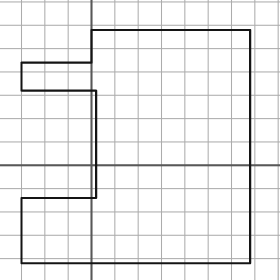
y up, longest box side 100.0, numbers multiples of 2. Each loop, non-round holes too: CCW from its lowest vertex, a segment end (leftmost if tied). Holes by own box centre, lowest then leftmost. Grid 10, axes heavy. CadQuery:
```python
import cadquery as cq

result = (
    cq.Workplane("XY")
    .moveTo(-30.0, -42.0)
    .lineTo(68.0, -42.0)
    .lineTo(68.0, 58.0)
    .lineTo(0.0, 58.0)
    .lineTo(0.0, 44.0)
    .lineTo(-30.0, 44.0)
    .lineTo(-30.0, 32.0)
    .lineTo(2.0, 32.0)
    .lineTo(2.0, -14.0)
    .lineTo(-30.0, -14.0)
    .close()
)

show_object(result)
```